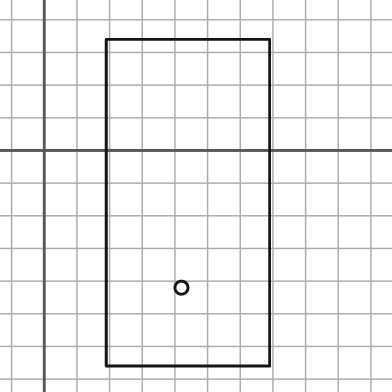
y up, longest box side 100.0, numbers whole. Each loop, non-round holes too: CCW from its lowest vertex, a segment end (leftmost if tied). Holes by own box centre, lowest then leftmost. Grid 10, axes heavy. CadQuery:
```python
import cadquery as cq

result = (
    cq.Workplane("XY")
    .moveTo(19.0, -66.0)
    .lineTo(69.0, -66.0)
    .lineTo(69.0, 34.0)
    .lineTo(19.0, 34.0)
    .close()
    .moveTo(42.0, -42.0)
    .circle(2.0)
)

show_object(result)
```